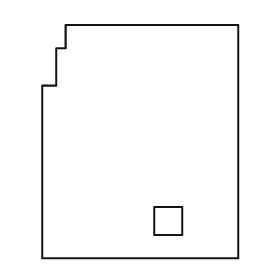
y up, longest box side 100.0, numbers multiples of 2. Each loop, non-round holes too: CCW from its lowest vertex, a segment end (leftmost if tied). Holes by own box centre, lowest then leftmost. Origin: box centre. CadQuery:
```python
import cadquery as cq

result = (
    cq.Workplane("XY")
    .moveTo(-42.0, -50.0)
    .lineTo(42.0, -50.0)
    .lineTo(42.0, 50.0)
    .lineTo(-32.0, 50.0)
    .lineTo(-32.0, 40.0)
    .lineTo(-36.0, 40.0)
    .lineTo(-36.0, 24.0)
    .lineTo(-42.0, 24.0)
    .close()
    .moveTo(6.0, -40.0)
    .lineTo(18.0, -40.0)
    .lineTo(18.0, -28.0)
    .lineTo(6.0, -28.0)
    .close()
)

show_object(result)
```